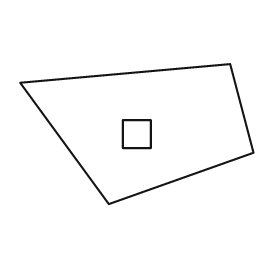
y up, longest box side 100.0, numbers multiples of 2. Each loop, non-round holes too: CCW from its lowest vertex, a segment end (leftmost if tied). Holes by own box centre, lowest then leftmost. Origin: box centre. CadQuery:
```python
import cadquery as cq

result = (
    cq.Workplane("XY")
    .moveTo(-12.0, -30.0)
    .lineTo(50.0, -8.0)
    .lineTo(40.0, 30.0)
    .lineTo(-50.0, 22.0)
    .close()
    .moveTo(-6.0, -6.0)
    .lineTo(6.0, -6.0)
    .lineTo(6.0, 6.0)
    .lineTo(-6.0, 6.0)
    .close()
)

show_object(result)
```